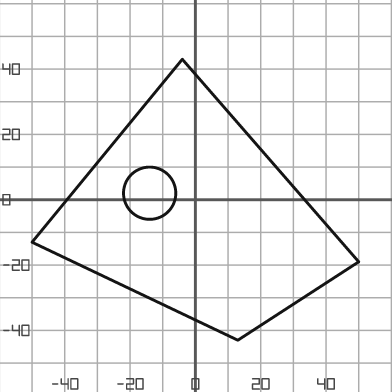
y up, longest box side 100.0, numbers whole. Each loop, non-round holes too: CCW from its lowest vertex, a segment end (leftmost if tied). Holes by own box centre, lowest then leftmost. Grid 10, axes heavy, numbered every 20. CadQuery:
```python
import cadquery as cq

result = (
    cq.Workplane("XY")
    .moveTo(13.0, -43.0)
    .lineTo(50.0, -19.0)
    .lineTo(-4.0, 43.0)
    .lineTo(-50.0, -13.0)
    .close()
    .moveTo(-14.0, 2.0)
    .circle(8.0)
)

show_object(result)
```